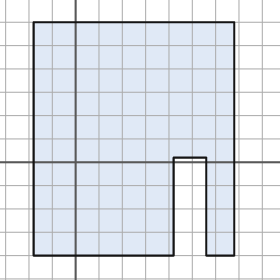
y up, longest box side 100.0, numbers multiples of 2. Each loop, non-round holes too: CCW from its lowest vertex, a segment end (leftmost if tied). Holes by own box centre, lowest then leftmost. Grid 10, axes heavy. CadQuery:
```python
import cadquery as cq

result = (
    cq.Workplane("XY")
    .moveTo(-18.0, -40.0)
    .lineTo(42.0, -40.0)
    .lineTo(42.0, 2.0)
    .lineTo(56.0, 2.0)
    .lineTo(56.0, -40.0)
    .lineTo(68.0, -40.0)
    .lineTo(68.0, 60.0)
    .lineTo(-18.0, 60.0)
    .close()
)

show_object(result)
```